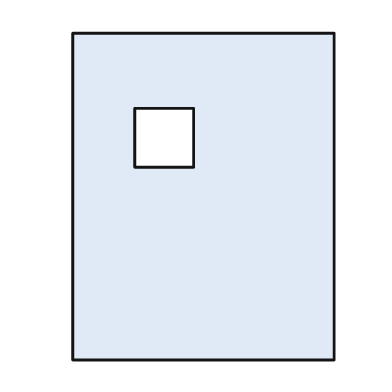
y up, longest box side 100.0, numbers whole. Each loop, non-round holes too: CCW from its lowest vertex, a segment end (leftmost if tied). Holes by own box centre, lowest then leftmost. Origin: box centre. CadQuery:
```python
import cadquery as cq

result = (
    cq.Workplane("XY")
    .moveTo(-40.0, -50.0)
    .lineTo(40.0, -50.0)
    .lineTo(40.0, 50.0)
    .lineTo(-40.0, 50.0)
    .close()
    .moveTo(-21.0, 9.0)
    .lineTo(-3.0, 9.0)
    .lineTo(-3.0, 27.0)
    .lineTo(-21.0, 27.0)
    .close()
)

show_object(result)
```